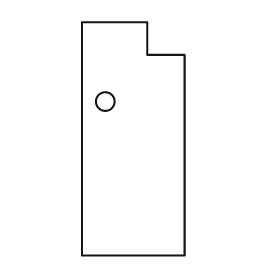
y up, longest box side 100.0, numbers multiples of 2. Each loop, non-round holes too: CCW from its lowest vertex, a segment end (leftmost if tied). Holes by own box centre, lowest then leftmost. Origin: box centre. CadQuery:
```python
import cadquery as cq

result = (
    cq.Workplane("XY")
    .moveTo(-22.0, -50.0)
    .lineTo(22.0, -50.0)
    .lineTo(22.0, 36.0)
    .lineTo(6.0, 36.0)
    .lineTo(6.0, 50.0)
    .lineTo(-22.0, 50.0)
    .close()
    .moveTo(-12.0, 16.0)
    .circle(4.0)
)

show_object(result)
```